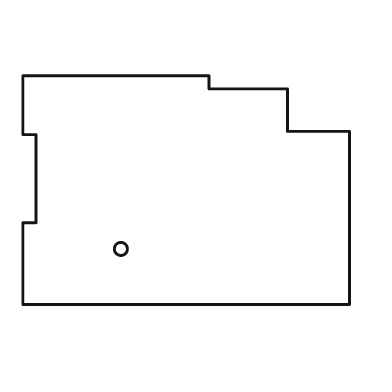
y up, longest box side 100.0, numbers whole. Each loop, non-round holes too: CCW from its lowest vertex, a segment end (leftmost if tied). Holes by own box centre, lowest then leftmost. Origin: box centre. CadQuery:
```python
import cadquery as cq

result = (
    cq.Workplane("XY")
    .moveTo(-50.0, -35.0)
    .lineTo(50.0, -35.0)
    .lineTo(50.0, 18.0)
    .lineTo(31.0, 18.0)
    .lineTo(31.0, 31.0)
    .lineTo(7.0, 31.0)
    .lineTo(7.0, 35.0)
    .lineTo(-50.0, 35.0)
    .lineTo(-50.0, 17.0)
    .lineTo(-46.0, 17.0)
    .lineTo(-46.0, -10.0)
    .lineTo(-50.0, -10.0)
    .close()
    .moveTo(-20.0, -18.0)
    .circle(2.0)
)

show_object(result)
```